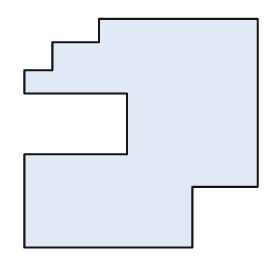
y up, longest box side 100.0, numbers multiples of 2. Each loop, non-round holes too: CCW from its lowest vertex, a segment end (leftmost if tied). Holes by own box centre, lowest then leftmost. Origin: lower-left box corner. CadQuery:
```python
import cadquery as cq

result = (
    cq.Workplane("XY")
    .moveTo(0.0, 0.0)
    .lineTo(72.0, 0.0)
    .lineTo(72.0, 26.0)
    .lineTo(100.0, 26.0)
    .lineTo(100.0, 98.0)
    .lineTo(32.0, 98.0)
    .lineTo(32.0, 88.0)
    .lineTo(12.0, 88.0)
    .lineTo(12.0, 76.0)
    .lineTo(0.0, 76.0)
    .lineTo(0.0, 66.0)
    .lineTo(44.0, 66.0)
    .lineTo(44.0, 40.0)
    .lineTo(0.0, 40.0)
    .close()
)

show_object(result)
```